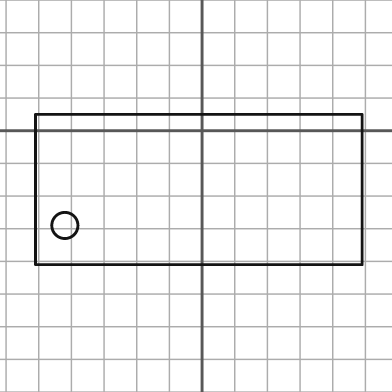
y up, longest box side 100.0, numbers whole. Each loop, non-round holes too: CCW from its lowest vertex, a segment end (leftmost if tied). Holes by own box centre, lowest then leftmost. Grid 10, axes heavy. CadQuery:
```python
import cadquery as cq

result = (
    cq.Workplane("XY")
    .moveTo(-51.0, -41.0)
    .lineTo(49.0, -41.0)
    .lineTo(49.0, 5.0)
    .lineTo(-51.0, 5.0)
    .close()
    .moveTo(-42.0, -29.0)
    .circle(4.0)
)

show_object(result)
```